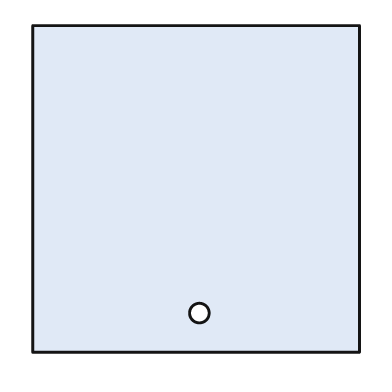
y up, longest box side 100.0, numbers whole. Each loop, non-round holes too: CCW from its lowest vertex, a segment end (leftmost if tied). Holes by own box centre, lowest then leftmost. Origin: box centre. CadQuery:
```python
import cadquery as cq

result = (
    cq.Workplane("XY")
    .moveTo(-50.0, -50.0)
    .lineTo(50.0, -50.0)
    .lineTo(50.0, 50.0)
    .lineTo(-50.0, 50.0)
    .close()
    .moveTo(1.0, -38.0)
    .circle(3.0)
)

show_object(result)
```